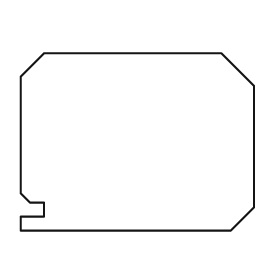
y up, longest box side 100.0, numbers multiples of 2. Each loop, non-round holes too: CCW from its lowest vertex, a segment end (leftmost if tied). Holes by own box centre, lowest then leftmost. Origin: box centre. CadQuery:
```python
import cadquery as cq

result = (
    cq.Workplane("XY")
    .moveTo(-50.0, -38.0)
    .lineTo(40.0, -38.0)
    .lineTo(50.0, -28.0)
    .lineTo(50.0, 24.0)
    .lineTo(36.0, 38.0)
    .lineTo(-40.0, 38.0)
    .lineTo(-50.0, 28.0)
    .lineTo(-50.0, -22.0)
    .lineTo(-46.0, -26.0)
    .lineTo(-40.0, -26.0)
    .lineTo(-40.0, -32.0)
    .lineTo(-50.0, -32.0)
    .close()
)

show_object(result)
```